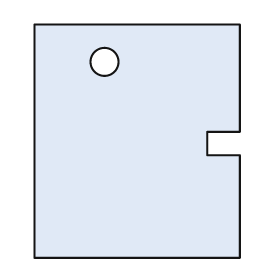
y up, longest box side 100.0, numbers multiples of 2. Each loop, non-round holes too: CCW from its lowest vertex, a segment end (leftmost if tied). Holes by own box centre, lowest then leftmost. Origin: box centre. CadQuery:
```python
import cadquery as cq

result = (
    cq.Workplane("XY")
    .moveTo(-44.0, -50.0)
    .lineTo(44.0, -50.0)
    .lineTo(44.0, -6.0)
    .lineTo(30.0, -6.0)
    .lineTo(30.0, 4.0)
    .lineTo(44.0, 4.0)
    .lineTo(44.0, 50.0)
    .lineTo(-44.0, 50.0)
    .close()
    .moveTo(-14.0, 34.0)
    .circle(6.0)
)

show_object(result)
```